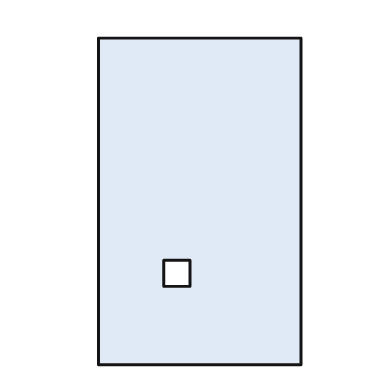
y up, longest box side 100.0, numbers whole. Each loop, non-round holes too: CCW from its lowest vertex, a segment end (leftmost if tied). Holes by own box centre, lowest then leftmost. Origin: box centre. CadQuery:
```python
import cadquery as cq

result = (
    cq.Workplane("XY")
    .moveTo(-31.0, -50.0)
    .lineTo(31.0, -50.0)
    .lineTo(31.0, 50.0)
    .lineTo(-31.0, 50.0)
    .close()
    .moveTo(-11.0, -26.0)
    .lineTo(-3.0, -26.0)
    .lineTo(-3.0, -18.0)
    .lineTo(-11.0, -18.0)
    .close()
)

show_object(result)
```